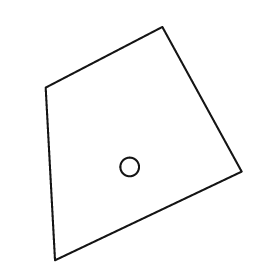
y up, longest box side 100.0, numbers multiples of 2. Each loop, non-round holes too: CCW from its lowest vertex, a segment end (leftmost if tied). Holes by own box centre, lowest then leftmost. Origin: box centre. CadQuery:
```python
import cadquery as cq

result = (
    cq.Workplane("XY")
    .moveTo(-38.0, -50.0)
    .lineTo(42.0, -12.0)
    .lineTo(8.0, 50.0)
    .lineTo(-42.0, 24.0)
    .close()
    .moveTo(-6.0, -10.0)
    .circle(4.0)
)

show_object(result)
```